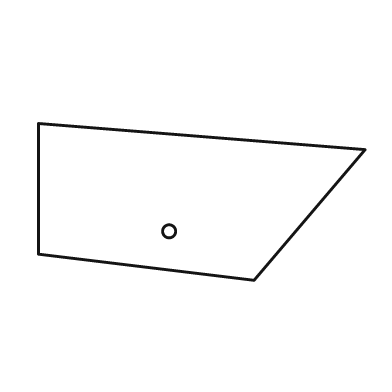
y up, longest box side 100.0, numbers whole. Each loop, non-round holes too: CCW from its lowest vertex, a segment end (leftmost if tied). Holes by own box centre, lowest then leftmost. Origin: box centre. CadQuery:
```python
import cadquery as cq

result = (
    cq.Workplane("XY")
    .moveTo(16.0, -24.0)
    .lineTo(50.0, 16.0)
    .lineTo(-50.0, 24.0)
    .lineTo(-50.0, -16.0)
    .close()
    .moveTo(-10.0, -9.0)
    .circle(2.0)
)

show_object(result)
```